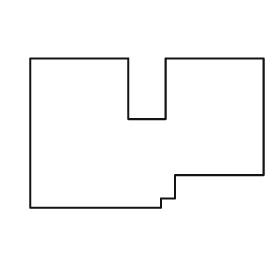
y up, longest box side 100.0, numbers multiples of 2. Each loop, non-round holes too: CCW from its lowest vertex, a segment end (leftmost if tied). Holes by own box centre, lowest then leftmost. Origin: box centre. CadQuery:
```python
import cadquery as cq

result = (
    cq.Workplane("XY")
    .moveTo(-50.0, -32.0)
    .lineTo(6.0, -32.0)
    .lineTo(6.0, -28.0)
    .lineTo(12.0, -28.0)
    .lineTo(12.0, -18.0)
    .lineTo(50.0, -18.0)
    .lineTo(50.0, 32.0)
    .lineTo(8.0, 32.0)
    .lineTo(8.0, 6.0)
    .lineTo(-8.0, 6.0)
    .lineTo(-8.0, 32.0)
    .lineTo(-50.0, 32.0)
    .close()
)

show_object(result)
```